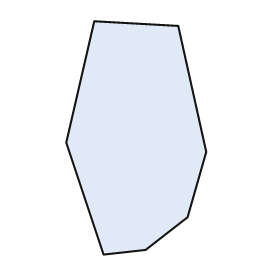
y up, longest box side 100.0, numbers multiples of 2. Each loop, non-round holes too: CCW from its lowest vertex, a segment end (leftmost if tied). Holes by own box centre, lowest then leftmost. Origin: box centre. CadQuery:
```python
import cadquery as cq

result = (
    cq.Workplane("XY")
    .moveTo(-14.0, -50.0)
    .lineTo(4.0, -48.0)
    .lineTo(22.0, -34.0)
    .lineTo(30.0, -6.0)
    .lineTo(18.0, 48.0)
    .lineTo(-18.0, 50.0)
    .lineTo(-30.0, -2.0)
    .close()
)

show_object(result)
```